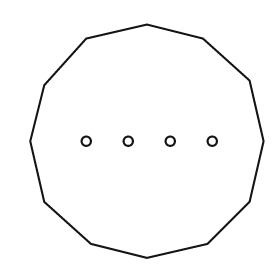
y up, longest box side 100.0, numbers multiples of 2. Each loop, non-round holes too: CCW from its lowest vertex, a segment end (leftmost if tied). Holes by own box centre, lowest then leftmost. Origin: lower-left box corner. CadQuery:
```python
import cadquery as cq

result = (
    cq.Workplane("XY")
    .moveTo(50.0, 0.0)
    .lineTo(76.0, 6.0)
    .lineTo(94.0, 24.0)
    .lineTo(100.0, 50.0)
    .lineTo(94.0, 76.0)
    .lineTo(74.0, 94.0)
    .lineTo(50.0, 100.0)
    .lineTo(24.0, 94.0)
    .lineTo(6.0, 74.0)
    .lineTo(0.0, 50.0)
    .lineTo(6.0, 24.0)
    .lineTo(26.0, 6.0)
    .close()
    .moveTo(24.0, 50.0)
    .circle(2.0)
    .moveTo(42.0, 50.0)
    .circle(2.0)
    .moveTo(60.0, 50.0)
    .circle(2.0)
    .moveTo(78.0, 50.0)
    .circle(2.0)
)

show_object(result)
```